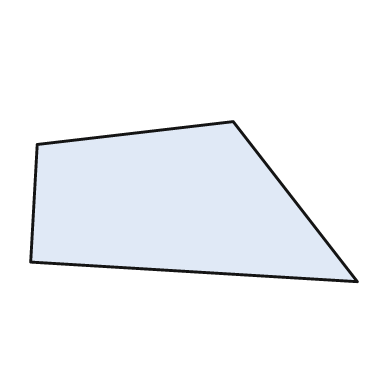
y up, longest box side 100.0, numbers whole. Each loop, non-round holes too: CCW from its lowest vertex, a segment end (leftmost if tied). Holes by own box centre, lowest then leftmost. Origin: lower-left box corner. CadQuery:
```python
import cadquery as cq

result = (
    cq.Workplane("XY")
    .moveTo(100.0, 0.0)
    .lineTo(62.0, 49.0)
    .lineTo(2.0, 42.0)
    .lineTo(0.0, 6.0)
    .close()
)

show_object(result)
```